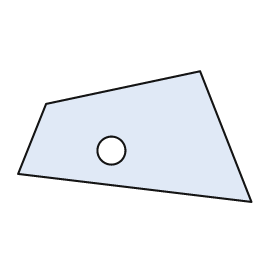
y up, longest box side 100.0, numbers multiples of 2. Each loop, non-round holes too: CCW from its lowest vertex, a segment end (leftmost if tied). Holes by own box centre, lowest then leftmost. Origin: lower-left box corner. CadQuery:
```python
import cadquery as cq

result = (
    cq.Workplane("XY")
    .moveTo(100.0, 0.0)
    .lineTo(78.0, 56.0)
    .lineTo(12.0, 42.0)
    .lineTo(0.0, 12.0)
    .close()
    .moveTo(40.0, 22.0)
    .circle(6.0)
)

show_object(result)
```